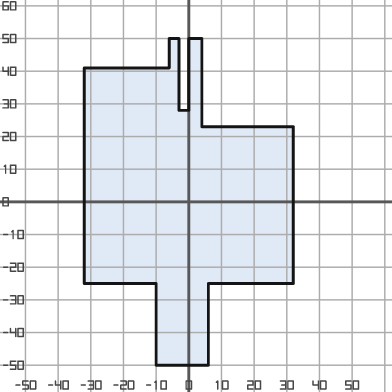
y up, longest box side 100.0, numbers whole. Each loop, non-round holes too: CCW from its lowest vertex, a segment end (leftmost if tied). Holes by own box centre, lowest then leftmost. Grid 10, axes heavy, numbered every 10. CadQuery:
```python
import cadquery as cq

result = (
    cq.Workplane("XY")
    .moveTo(-10.0, -50.0)
    .lineTo(6.0, -50.0)
    .lineTo(6.0, -25.0)
    .lineTo(32.0, -25.0)
    .lineTo(32.0, 23.0)
    .lineTo(4.0, 23.0)
    .lineTo(4.0, 50.0)
    .lineTo(0.0, 50.0)
    .lineTo(0.0, 28.0)
    .lineTo(-3.0, 28.0)
    .lineTo(-3.0, 50.0)
    .lineTo(-6.0, 50.0)
    .lineTo(-6.0, 41.0)
    .lineTo(-32.0, 41.0)
    .lineTo(-32.0, -25.0)
    .lineTo(-10.0, -25.0)
    .close()
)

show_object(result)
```